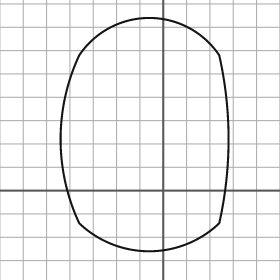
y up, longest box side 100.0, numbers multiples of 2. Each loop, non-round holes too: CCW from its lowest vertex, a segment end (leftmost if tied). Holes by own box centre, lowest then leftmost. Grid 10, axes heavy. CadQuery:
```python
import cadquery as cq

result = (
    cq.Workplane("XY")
    .moveTo(-36.0, -14.0)
    .threePointArc((-6.0, -26.0), (24.0, -14.0))
    .threePointArc((28.0, 22.0), (24.0, 58.0))
    .threePointArc((-6.0, 74.0), (-36.0, 58.0))
    .threePointArc((-44.0, 22.0), (-36.0, -14.0))
    .close()
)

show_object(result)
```